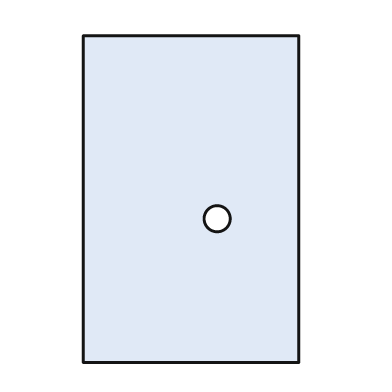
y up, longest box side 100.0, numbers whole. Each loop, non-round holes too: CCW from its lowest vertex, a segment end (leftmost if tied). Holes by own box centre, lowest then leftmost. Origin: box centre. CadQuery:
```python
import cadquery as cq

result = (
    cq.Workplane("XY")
    .moveTo(-33.0, -50.0)
    .lineTo(33.0, -50.0)
    .lineTo(33.0, 50.0)
    .lineTo(-33.0, 50.0)
    .close()
    .moveTo(8.0, -6.0)
    .circle(4.0)
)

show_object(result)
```